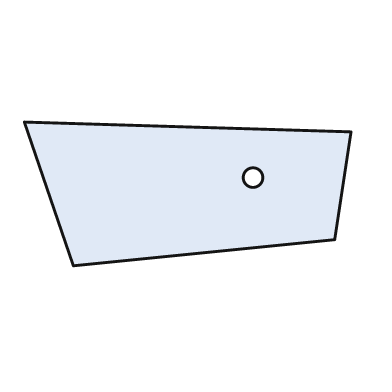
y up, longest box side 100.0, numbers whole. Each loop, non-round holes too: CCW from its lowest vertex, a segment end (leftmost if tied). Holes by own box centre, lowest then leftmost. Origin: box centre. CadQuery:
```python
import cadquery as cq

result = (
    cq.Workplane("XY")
    .moveTo(-35.0, -22.0)
    .lineTo(45.0, -14.0)
    .lineTo(50.0, 19.0)
    .lineTo(-50.0, 22.0)
    .close()
    .moveTo(20.0, 5.0)
    .circle(3.0)
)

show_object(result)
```